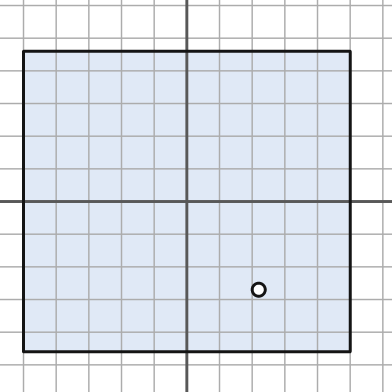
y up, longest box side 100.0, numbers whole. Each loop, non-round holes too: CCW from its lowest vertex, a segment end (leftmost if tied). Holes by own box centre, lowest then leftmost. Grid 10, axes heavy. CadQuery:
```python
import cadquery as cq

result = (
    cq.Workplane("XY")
    .moveTo(-50.0, -46.0)
    .lineTo(50.0, -46.0)
    .lineTo(50.0, 46.0)
    .lineTo(-50.0, 46.0)
    .close()
    .moveTo(22.0, -27.0)
    .circle(2.0)
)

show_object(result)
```